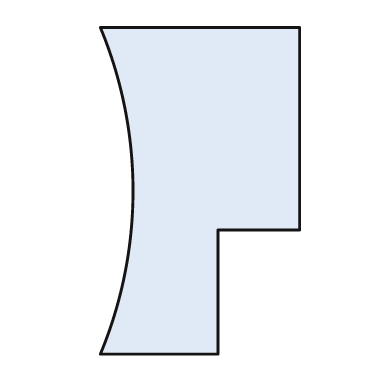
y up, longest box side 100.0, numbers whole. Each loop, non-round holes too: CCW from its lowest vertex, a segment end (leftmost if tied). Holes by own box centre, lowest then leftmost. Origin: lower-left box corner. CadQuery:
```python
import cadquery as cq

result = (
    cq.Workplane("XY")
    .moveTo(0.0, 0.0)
    .lineTo(36.0, 0.0)
    .lineTo(36.0, 38.0)
    .lineTo(61.0, 38.0)
    .lineTo(61.0, 100.0)
    .lineTo(0.0, 100.0)
    .threePointArc((10.0, 50.0), (0.0, 0.0))
    .close()
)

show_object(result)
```